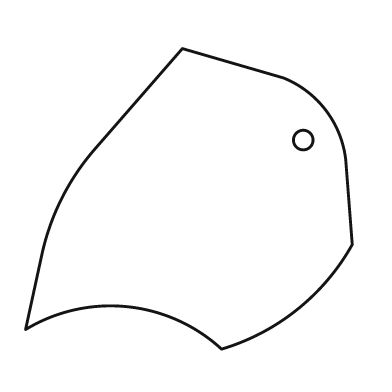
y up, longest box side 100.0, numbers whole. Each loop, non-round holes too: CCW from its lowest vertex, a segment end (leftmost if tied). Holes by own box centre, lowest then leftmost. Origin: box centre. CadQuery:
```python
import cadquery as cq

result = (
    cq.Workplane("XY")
    .moveTo(10.0, -46.0)
    .threePointArc((33.0, -34.0), (50.0, -14.0))
    .lineTo(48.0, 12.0)
    .threePointArc((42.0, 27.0), (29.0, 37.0))
    .lineTo(-2.0, 46.0)
    .lineTo(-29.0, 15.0)
    .threePointArc((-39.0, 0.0), (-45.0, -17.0))
    .lineTo(-50.0, -40.0)
    .threePointArc((-19.0, -33.0), (10.0, -46.0))
    .close()
    .moveTo(35.0, 18.0)
    .circle(3.0)
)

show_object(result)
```